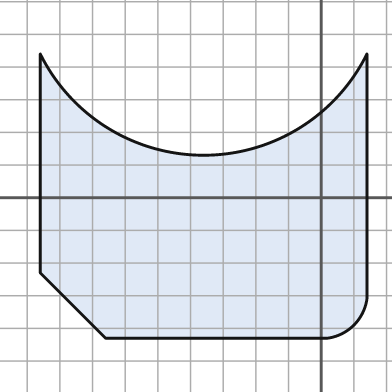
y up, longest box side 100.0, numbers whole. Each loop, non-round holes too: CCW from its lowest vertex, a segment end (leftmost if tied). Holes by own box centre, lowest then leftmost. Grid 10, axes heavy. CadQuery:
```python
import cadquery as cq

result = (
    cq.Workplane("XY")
    .moveTo(-66.0, -43.0)
    .lineTo(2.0, -43.0)
    .threePointArc((10.0, -39.0), (14.0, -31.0))
    .lineTo(14.0, 44.0)
    .threePointArc((-36.0, 13.0), (-86.0, 44.0))
    .lineTo(-86.0, -23.0)
    .close()
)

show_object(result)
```